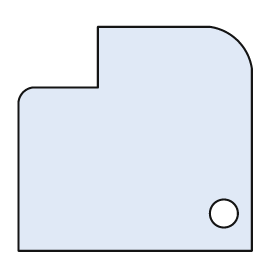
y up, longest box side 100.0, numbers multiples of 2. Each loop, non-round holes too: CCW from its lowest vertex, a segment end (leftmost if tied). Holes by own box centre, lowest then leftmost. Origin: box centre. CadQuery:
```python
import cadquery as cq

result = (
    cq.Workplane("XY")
    .moveTo(-50.0, -48.0)
    .lineTo(50.0, -48.0)
    .lineTo(50.0, 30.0)
    .threePointArc((44.0, 42.0), (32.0, 48.0))
    .lineTo(-16.0, 48.0)
    .lineTo(-16.0, 22.0)
    .lineTo(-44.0, 22.0)
    .threePointArc((-48.0, 20.0), (-50.0, 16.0))
    .close()
    .moveTo(38.0, -32.0)
    .circle(6.0)
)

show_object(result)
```